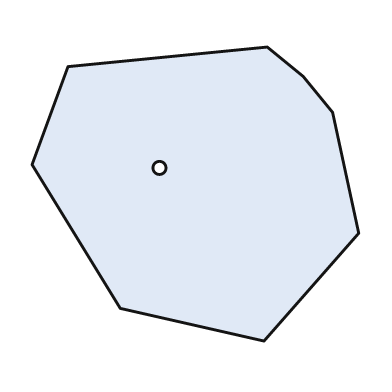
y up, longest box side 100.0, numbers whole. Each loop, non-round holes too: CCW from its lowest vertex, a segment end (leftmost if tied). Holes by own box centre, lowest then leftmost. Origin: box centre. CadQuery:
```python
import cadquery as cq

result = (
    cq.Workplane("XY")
    .moveTo(21.0, -45.0)
    .lineTo(50.0, -12.0)
    .lineTo(42.0, 25.0)
    .lineTo(33.0, 36.0)
    .lineTo(22.0, 45.0)
    .lineTo(-39.0, 39.0)
    .lineTo(-50.0, 9.0)
    .lineTo(-23.0, -35.0)
    .close()
    .moveTo(-11.0, 8.0)
    .circle(2.0)
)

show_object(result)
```